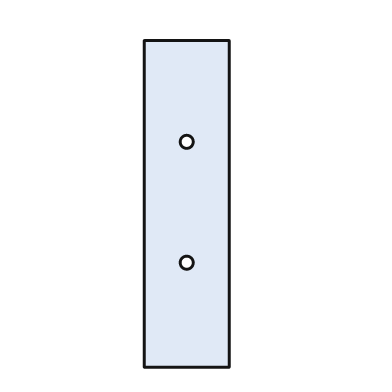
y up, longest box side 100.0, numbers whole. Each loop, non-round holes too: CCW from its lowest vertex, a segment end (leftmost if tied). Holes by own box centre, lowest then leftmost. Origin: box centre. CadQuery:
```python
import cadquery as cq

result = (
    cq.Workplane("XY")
    .moveTo(-13.0, -50.0)
    .lineTo(13.0, -50.0)
    .lineTo(13.0, 50.0)
    .lineTo(-13.0, 50.0)
    .close()
    .moveTo(0.0, -18.0)
    .circle(2.0)
    .moveTo(0.0, 19.0)
    .circle(2.0)
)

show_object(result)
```